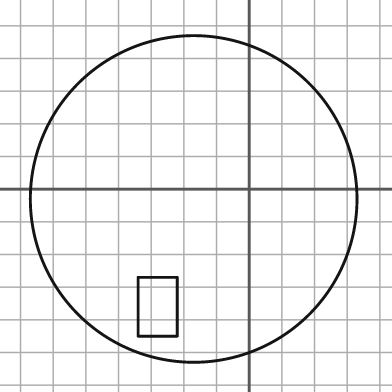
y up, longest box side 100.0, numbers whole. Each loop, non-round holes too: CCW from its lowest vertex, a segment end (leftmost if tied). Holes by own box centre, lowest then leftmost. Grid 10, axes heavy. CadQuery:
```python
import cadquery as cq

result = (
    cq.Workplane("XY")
    .moveTo(-17.0, -3.0)
    .circle(50.0)
    .moveTo(-34.0, -45.0)
    .lineTo(-22.0, -45.0)
    .lineTo(-22.0, -27.0)
    .lineTo(-34.0, -27.0)
    .close()
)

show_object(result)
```